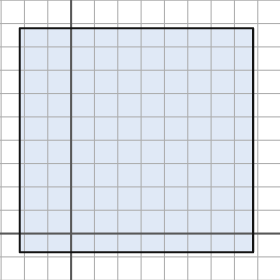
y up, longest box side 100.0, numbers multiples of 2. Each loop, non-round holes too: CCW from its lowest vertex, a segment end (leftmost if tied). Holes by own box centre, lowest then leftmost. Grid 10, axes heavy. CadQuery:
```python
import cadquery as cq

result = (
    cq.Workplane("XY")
    .moveTo(-22.0, -8.0)
    .lineTo(78.0, -8.0)
    .lineTo(78.0, 88.0)
    .lineTo(-22.0, 88.0)
    .close()
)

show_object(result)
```